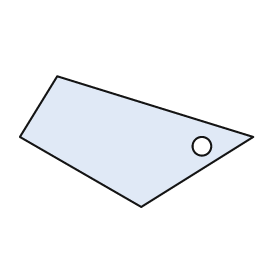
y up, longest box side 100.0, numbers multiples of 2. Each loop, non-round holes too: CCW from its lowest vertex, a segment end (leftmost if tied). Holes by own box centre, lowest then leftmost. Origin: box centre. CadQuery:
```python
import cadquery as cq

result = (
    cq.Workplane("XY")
    .moveTo(2.0, -28.0)
    .lineTo(50.0, 2.0)
    .lineTo(-34.0, 28.0)
    .lineTo(-50.0, 2.0)
    .close()
    .moveTo(28.0, -2.0)
    .circle(4.0)
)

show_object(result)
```